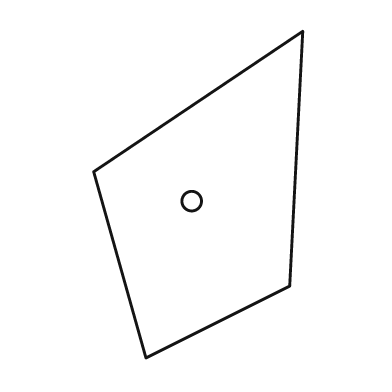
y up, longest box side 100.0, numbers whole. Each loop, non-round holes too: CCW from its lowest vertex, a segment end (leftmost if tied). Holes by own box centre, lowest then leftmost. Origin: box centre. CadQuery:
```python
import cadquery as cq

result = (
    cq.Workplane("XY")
    .moveTo(-16.0, -50.0)
    .lineTo(28.0, -28.0)
    .lineTo(32.0, 50.0)
    .lineTo(-32.0, 7.0)
    .close()
    .moveTo(-2.0, -2.0)
    .circle(3.0)
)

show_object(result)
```